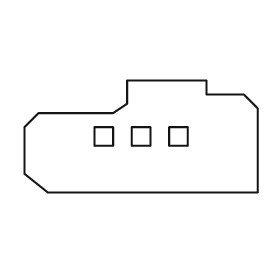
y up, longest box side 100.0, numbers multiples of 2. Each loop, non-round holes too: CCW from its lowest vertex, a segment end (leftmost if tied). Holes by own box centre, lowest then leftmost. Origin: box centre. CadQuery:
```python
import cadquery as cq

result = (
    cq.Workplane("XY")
    .moveTo(-40.0, -24.0)
    .lineTo(50.0, -24.0)
    .lineTo(50.0, 12.0)
    .lineTo(44.0, 18.0)
    .lineTo(28.0, 18.0)
    .lineTo(28.0, 24.0)
    .lineTo(-6.0, 24.0)
    .lineTo(-6.0, 14.0)
    .lineTo(-12.0, 10.0)
    .lineTo(-44.0, 10.0)
    .lineTo(-50.0, 4.0)
    .lineTo(-50.0, -16.0)
    .close()
    .moveTo(-20.0, -4.0)
    .lineTo(-12.0, -4.0)
    .lineTo(-12.0, 4.0)
    .lineTo(-20.0, 4.0)
    .close()
    .moveTo(-4.0, -4.0)
    .lineTo(4.0, -4.0)
    .lineTo(4.0, 4.0)
    .lineTo(-4.0, 4.0)
    .close()
    .moveTo(12.0, -4.0)
    .lineTo(20.0, -4.0)
    .lineTo(20.0, 4.0)
    .lineTo(12.0, 4.0)
    .close()
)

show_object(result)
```